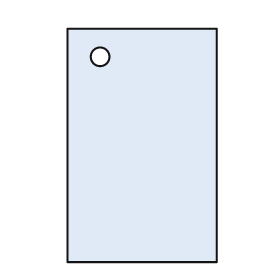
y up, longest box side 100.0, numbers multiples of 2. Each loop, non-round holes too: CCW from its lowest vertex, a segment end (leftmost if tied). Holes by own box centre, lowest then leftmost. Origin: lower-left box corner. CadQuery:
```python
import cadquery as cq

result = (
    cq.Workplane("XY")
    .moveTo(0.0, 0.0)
    .lineTo(64.0, 0.0)
    .lineTo(64.0, 100.0)
    .lineTo(0.0, 100.0)
    .close()
    .moveTo(14.0, 88.0)
    .circle(4.0)
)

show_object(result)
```